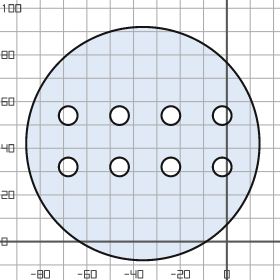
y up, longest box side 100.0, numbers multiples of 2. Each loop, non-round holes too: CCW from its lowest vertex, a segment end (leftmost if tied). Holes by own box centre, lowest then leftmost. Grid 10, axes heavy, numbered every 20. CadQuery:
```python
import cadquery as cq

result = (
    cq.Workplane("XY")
    .moveTo(-36.0, 42.0)
    .circle(50.0)
    .moveTo(-68.0, 32.0)
    .circle(4.0)
    .moveTo(-46.0, 32.0)
    .circle(4.0)
    .moveTo(-24.0, 32.0)
    .circle(4.0)
    .moveTo(-2.0, 32.0)
    .circle(4.0)
    .moveTo(-68.0, 54.0)
    .circle(4.0)
    .moveTo(-46.0, 54.0)
    .circle(4.0)
    .moveTo(-24.0, 54.0)
    .circle(4.0)
    .moveTo(-2.0, 54.0)
    .circle(4.0)
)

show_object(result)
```